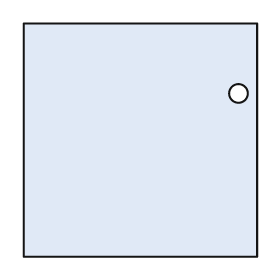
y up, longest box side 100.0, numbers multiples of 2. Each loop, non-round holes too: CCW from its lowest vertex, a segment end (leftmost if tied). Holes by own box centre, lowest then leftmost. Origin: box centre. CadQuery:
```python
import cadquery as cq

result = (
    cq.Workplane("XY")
    .moveTo(-50.0, -50.0)
    .lineTo(50.0, -50.0)
    .lineTo(50.0, 50.0)
    .lineTo(-50.0, 50.0)
    .close()
    .moveTo(42.0, 20.0)
    .circle(4.0)
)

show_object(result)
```